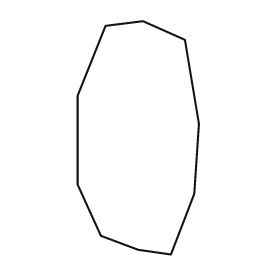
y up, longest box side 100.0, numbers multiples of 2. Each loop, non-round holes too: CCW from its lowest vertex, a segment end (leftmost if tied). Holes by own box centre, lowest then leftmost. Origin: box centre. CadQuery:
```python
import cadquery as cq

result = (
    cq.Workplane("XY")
    .moveTo(14.0, -50.0)
    .lineTo(24.0, -24.0)
    .lineTo(26.0, 6.0)
    .lineTo(20.0, 42.0)
    .lineTo(2.0, 50.0)
    .lineTo(-14.0, 48.0)
    .lineTo(-26.0, 18.0)
    .lineTo(-26.0, -20.0)
    .lineTo(-16.0, -42.0)
    .lineTo(0.0, -48.0)
    .close()
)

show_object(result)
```